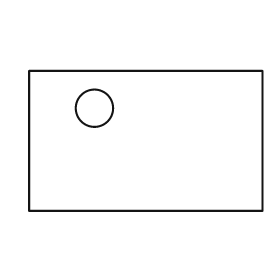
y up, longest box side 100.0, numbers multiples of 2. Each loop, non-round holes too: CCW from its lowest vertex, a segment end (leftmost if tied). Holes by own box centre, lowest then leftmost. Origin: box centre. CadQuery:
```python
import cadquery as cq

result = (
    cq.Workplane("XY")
    .moveTo(-50.0, -30.0)
    .lineTo(50.0, -30.0)
    .lineTo(50.0, 30.0)
    .lineTo(-50.0, 30.0)
    .close()
    .moveTo(-22.0, 14.0)
    .circle(8.0)
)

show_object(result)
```